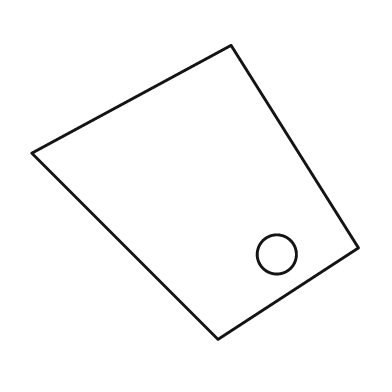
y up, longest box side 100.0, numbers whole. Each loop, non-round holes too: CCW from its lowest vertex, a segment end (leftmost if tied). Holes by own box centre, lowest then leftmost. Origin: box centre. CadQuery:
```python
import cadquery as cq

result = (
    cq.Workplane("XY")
    .moveTo(7.0, -45.0)
    .lineTo(50.0, -17.0)
    .lineTo(11.0, 45.0)
    .lineTo(-50.0, 12.0)
    .close()
    .moveTo(25.0, -19.0)
    .circle(6.0)
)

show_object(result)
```